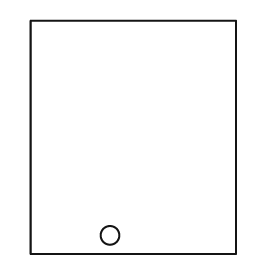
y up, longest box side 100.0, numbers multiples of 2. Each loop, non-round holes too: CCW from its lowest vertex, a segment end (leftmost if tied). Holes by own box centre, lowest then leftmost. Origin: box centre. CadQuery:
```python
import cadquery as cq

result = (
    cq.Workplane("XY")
    .moveTo(-44.0, -50.0)
    .lineTo(44.0, -50.0)
    .lineTo(44.0, 50.0)
    .lineTo(-44.0, 50.0)
    .close()
    .moveTo(-10.0, -42.0)
    .circle(4.0)
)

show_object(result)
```